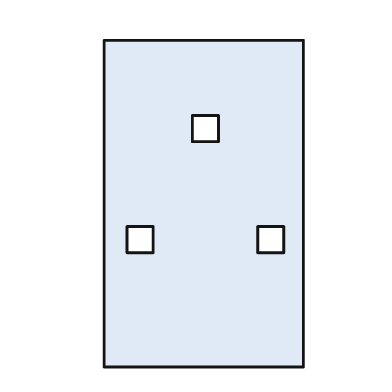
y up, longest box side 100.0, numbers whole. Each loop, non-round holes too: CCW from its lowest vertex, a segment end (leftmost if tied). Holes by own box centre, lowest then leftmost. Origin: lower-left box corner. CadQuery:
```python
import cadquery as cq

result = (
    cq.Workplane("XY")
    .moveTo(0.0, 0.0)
    .lineTo(61.0, 0.0)
    .lineTo(61.0, 100.0)
    .lineTo(0.0, 100.0)
    .close()
    .moveTo(7.0, 35.0)
    .lineTo(15.0, 35.0)
    .lineTo(15.0, 43.0)
    .lineTo(7.0, 43.0)
    .close()
    .moveTo(47.0, 35.0)
    .lineTo(55.0, 35.0)
    .lineTo(55.0, 43.0)
    .lineTo(47.0, 43.0)
    .close()
    .moveTo(27.0, 69.0)
    .lineTo(35.0, 69.0)
    .lineTo(35.0, 77.0)
    .lineTo(27.0, 77.0)
    .close()
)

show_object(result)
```